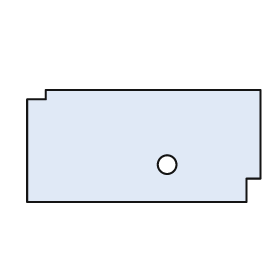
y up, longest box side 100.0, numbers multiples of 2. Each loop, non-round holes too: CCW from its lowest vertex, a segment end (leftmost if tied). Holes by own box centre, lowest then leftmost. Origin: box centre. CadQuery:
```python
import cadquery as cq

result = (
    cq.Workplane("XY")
    .moveTo(-50.0, -24.0)
    .lineTo(44.0, -24.0)
    .lineTo(44.0, -14.0)
    .lineTo(50.0, -14.0)
    .lineTo(50.0, 24.0)
    .lineTo(-42.0, 24.0)
    .lineTo(-42.0, 20.0)
    .lineTo(-50.0, 20.0)
    .close()
    .moveTo(10.0, -8.0)
    .circle(4.0)
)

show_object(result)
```